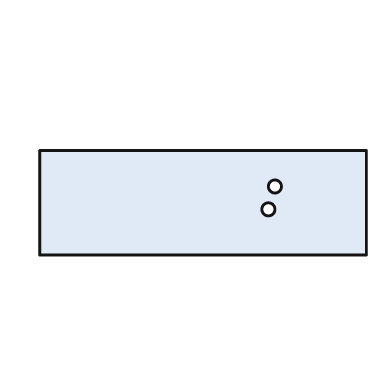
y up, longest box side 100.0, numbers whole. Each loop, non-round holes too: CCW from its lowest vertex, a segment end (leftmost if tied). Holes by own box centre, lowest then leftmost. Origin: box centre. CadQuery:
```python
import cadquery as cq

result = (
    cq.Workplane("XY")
    .moveTo(-50.0, -16.0)
    .lineTo(50.0, -16.0)
    .lineTo(50.0, 16.0)
    .lineTo(-50.0, 16.0)
    .close()
    .moveTo(20.0, -2.0)
    .circle(2.0)
    .moveTo(22.0, 5.0)
    .circle(2.0)
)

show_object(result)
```